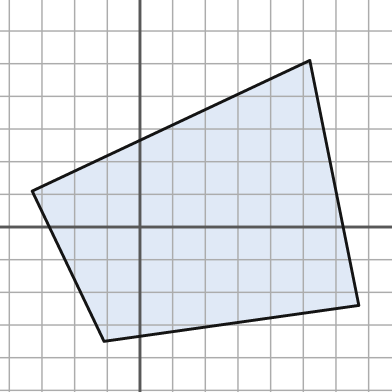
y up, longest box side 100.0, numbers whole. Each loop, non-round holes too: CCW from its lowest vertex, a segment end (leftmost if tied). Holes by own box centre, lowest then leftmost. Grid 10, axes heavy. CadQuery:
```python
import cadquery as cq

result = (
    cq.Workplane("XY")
    .moveTo(-11.0, -35.0)
    .lineTo(67.0, -24.0)
    .lineTo(52.0, 51.0)
    .lineTo(-33.0, 11.0)
    .close()
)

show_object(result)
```